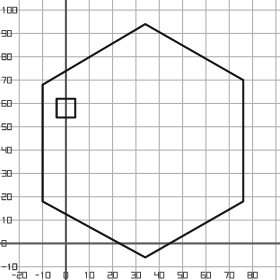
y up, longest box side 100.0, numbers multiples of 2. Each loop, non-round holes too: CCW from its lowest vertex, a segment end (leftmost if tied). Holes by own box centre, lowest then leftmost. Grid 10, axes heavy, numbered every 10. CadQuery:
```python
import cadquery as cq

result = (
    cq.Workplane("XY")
    .moveTo(34.0, -6.0)
    .lineTo(76.0, 18.0)
    .lineTo(76.0, 70.0)
    .lineTo(34.0, 94.0)
    .lineTo(-10.0, 68.0)
    .lineTo(-10.0, 18.0)
    .close()
    .moveTo(-4.0, 54.0)
    .lineTo(4.0, 54.0)
    .lineTo(4.0, 62.0)
    .lineTo(-4.0, 62.0)
    .close()
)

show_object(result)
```